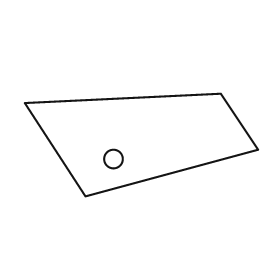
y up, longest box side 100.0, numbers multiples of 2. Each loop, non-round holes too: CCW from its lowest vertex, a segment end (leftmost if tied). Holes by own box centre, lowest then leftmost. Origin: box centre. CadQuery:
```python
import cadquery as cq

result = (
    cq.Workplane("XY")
    .moveTo(-24.0, -22.0)
    .lineTo(50.0, -2.0)
    .lineTo(34.0, 22.0)
    .lineTo(-50.0, 18.0)
    .close()
    .moveTo(-12.0, -6.0)
    .circle(4.0)
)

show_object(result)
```